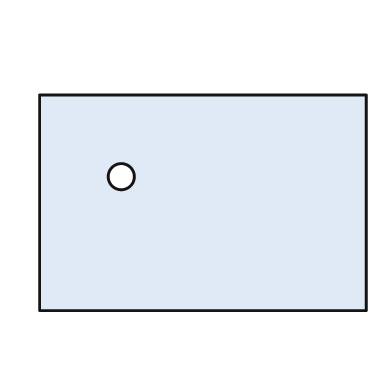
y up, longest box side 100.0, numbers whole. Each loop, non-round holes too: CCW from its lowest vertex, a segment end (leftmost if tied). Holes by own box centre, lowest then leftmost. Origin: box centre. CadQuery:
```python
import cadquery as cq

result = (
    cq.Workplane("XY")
    .moveTo(-50.0, -33.0)
    .lineTo(50.0, -33.0)
    .lineTo(50.0, 33.0)
    .lineTo(-50.0, 33.0)
    .close()
    .moveTo(-25.0, 8.0)
    .circle(4.0)
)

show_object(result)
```